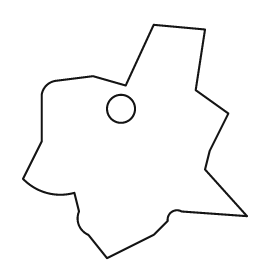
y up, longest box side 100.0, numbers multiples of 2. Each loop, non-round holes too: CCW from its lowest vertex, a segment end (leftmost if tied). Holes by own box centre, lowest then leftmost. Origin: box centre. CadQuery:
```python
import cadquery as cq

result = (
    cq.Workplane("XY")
    .moveTo(-12.0, -50.0)
    .lineTo(8.0, -40.0)
    .lineTo(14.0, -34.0)
    .threePointArc((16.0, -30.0), (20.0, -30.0))
    .lineTo(48.0, -32.0)
    .lineTo(30.0, -12.0)
    .lineTo(32.0, -4.0)
    .lineTo(40.0, 12.0)
    .lineTo(26.0, 22.0)
    .lineTo(30.0, 48.0)
    .lineTo(8.0, 50.0)
    .lineTo(-4.0, 24.0)
    .lineTo(-18.0, 28.0)
    .lineTo(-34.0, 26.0)
    .threePointArc((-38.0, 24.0), (-40.0, 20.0))
    .lineTo(-40.0, 0.0)
    .lineTo(-48.0, -16.0)
    .threePointArc((-38.0, -22.0), (-26.0, -22.0))
    .lineTo(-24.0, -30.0)
    .threePointArc((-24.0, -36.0), (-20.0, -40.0))
    .close()
    .moveTo(-6.0, 14.0)
    .circle(6.0)
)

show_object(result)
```